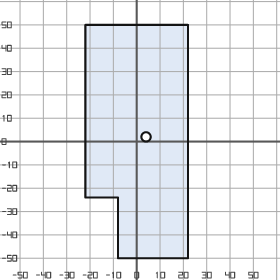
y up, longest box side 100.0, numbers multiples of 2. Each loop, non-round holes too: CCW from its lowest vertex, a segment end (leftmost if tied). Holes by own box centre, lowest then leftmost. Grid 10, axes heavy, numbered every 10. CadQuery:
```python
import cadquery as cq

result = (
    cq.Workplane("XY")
    .moveTo(-8.0, -50.0)
    .lineTo(22.0, -50.0)
    .lineTo(22.0, 50.0)
    .lineTo(-22.0, 50.0)
    .lineTo(-22.0, -24.0)
    .lineTo(-8.0, -24.0)
    .close()
    .moveTo(4.0, 2.0)
    .circle(2.0)
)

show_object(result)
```